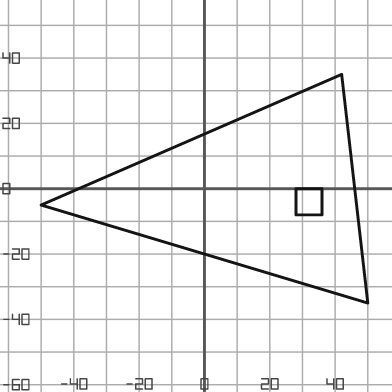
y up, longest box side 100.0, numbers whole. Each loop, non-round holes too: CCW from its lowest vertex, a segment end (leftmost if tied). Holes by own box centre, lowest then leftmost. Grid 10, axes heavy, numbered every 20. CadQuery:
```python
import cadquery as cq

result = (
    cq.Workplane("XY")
    .moveTo(50.0, -35.0)
    .lineTo(42.0, 35.0)
    .lineTo(-50.0, -5.0)
    .close()
    .moveTo(28.0, -8.0)
    .lineTo(36.0, -8.0)
    .lineTo(36.0, 0.0)
    .lineTo(28.0, 0.0)
    .close()
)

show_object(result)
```